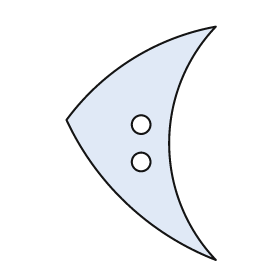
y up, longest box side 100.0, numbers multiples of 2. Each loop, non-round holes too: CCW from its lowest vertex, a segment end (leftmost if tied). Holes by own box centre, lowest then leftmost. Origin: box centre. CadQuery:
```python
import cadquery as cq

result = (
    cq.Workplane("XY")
    .moveTo(32.0, -50.0)
    .threePointArc((12.0, 0.0), (32.0, 50.0))
    .threePointArc((-4.0, 36.0), (-32.0, 10.0))
    .threePointArc((-6.0, -26.0), (32.0, -50.0))
    .close()
    .moveTo(0.0, -8.0)
    .circle(4.0)
    .moveTo(0.0, 8.0)
    .circle(4.0)
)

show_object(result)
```